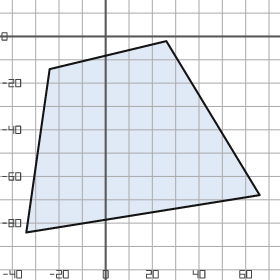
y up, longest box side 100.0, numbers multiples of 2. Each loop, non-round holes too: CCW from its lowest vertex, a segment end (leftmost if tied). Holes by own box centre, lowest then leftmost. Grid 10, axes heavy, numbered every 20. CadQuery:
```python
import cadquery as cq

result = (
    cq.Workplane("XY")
    .moveTo(-34.0, -84.0)
    .lineTo(66.0, -68.0)
    .lineTo(26.0, -2.0)
    .lineTo(-24.0, -14.0)
    .close()
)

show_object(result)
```